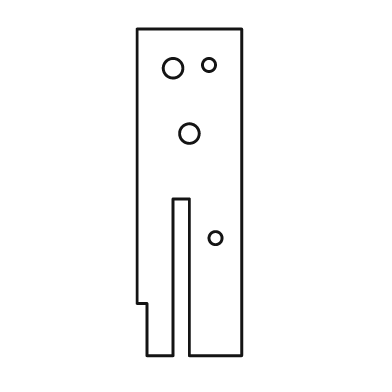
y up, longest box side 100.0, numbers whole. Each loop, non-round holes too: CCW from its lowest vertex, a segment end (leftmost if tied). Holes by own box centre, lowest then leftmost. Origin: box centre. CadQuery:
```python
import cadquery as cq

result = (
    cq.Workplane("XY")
    .moveTo(-13.0, -50.0)
    .lineTo(-5.0, -50.0)
    .lineTo(-5.0, -2.0)
    .lineTo(0.0, -2.0)
    .lineTo(0.0, -50.0)
    .lineTo(16.0, -50.0)
    .lineTo(16.0, 50.0)
    .lineTo(-16.0, 50.0)
    .lineTo(-16.0, -34.0)
    .lineTo(-13.0, -34.0)
    .close()
    .moveTo(8.0, -14.0)
    .circle(2.0)
    .moveTo(0.0, 18.0)
    .circle(3.0)
    .moveTo(-5.0, 38.0)
    .circle(3.0)
    .moveTo(6.0, 39.0)
    .circle(2.0)
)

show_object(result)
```